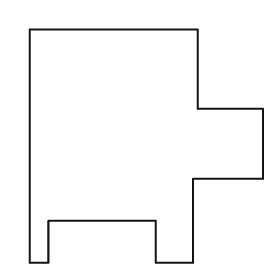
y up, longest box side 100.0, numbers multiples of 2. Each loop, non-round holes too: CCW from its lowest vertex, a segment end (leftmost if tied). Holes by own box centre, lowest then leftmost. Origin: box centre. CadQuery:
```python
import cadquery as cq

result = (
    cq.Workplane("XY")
    .moveTo(-50.0, -50.0)
    .lineTo(-42.0, -50.0)
    .lineTo(-42.0, -32.0)
    .lineTo(4.0, -32.0)
    .lineTo(4.0, -50.0)
    .lineTo(20.0, -50.0)
    .lineTo(20.0, -14.0)
    .lineTo(50.0, -14.0)
    .lineTo(50.0, 16.0)
    .lineTo(22.0, 16.0)
    .lineTo(22.0, 50.0)
    .lineTo(-50.0, 50.0)
    .close()
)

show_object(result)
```